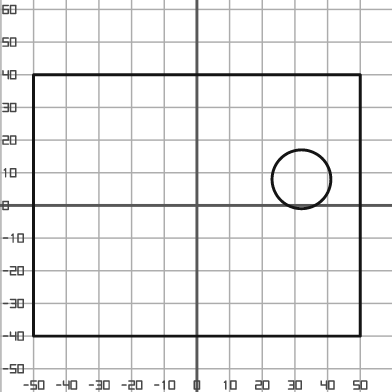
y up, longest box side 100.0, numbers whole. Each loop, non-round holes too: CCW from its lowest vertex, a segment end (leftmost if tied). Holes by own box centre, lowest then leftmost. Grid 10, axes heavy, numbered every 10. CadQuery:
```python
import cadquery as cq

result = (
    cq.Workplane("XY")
    .moveTo(-50.0, -40.0)
    .lineTo(50.0, -40.0)
    .lineTo(50.0, 40.0)
    .lineTo(-50.0, 40.0)
    .close()
    .moveTo(32.0, 8.0)
    .circle(9.0)
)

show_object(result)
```